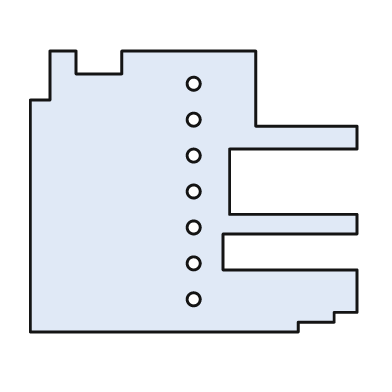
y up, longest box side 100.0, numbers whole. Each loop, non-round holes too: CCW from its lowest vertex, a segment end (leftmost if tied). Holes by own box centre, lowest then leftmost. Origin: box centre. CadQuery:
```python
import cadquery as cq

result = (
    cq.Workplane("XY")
    .moveTo(-50.0, -43.0)
    .lineTo(32.0, -43.0)
    .lineTo(32.0, -40.0)
    .lineTo(43.0, -40.0)
    .lineTo(43.0, -37.0)
    .lineTo(50.0, -37.0)
    .lineTo(50.0, -24.0)
    .lineTo(9.0, -24.0)
    .lineTo(9.0, -13.0)
    .lineTo(50.0, -13.0)
    .lineTo(50.0, -7.0)
    .lineTo(11.0, -7.0)
    .lineTo(11.0, 13.0)
    .lineTo(50.0, 13.0)
    .lineTo(50.0, 20.0)
    .lineTo(19.0, 20.0)
    .lineTo(19.0, 43.0)
    .lineTo(-22.0, 43.0)
    .lineTo(-22.0, 36.0)
    .lineTo(-36.0, 36.0)
    .lineTo(-36.0, 43.0)
    .lineTo(-44.0, 43.0)
    .lineTo(-44.0, 28.0)
    .lineTo(-50.0, 28.0)
    .close()
    .moveTo(0.0, -33.0)
    .circle(2.0)
    .moveTo(0.0, -22.0)
    .circle(2.0)
    .moveTo(0.0, -11.0)
    .circle(2.0)
    .moveTo(0.0, 0.0)
    .circle(2.0)
    .moveTo(0.0, 11.0)
    .circle(2.0)
    .moveTo(0.0, 22.0)
    .circle(2.0)
    .moveTo(0.0, 33.0)
    .circle(2.0)
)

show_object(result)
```